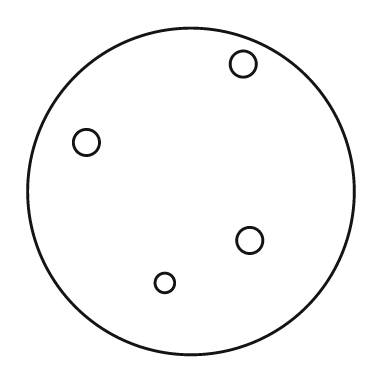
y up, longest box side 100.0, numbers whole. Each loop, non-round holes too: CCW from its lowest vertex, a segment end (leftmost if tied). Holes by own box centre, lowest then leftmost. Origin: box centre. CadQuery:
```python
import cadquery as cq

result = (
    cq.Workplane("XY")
    .moveTo(0.0, 0.0)
    .circle(50.0)
    .moveTo(-8.0, -28.0)
    .circle(3.0)
    .moveTo(18.0, -15.0)
    .circle(4.0)
    .moveTo(-32.0, 15.0)
    .circle(4.0)
    .moveTo(16.0, 39.0)
    .circle(4.0)
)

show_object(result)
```